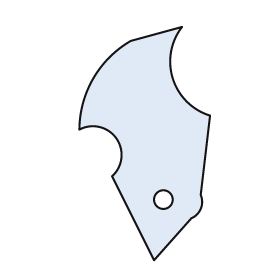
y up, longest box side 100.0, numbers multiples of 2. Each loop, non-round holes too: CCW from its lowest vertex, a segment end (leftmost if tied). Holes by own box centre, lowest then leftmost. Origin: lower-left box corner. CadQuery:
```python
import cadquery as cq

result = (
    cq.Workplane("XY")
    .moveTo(32.0, 0.0)
    .lineTo(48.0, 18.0)
    .threePointArc((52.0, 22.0), (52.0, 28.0))
    .lineTo(56.0, 62.0)
    .threePointArc((40.0, 78.0), (44.0, 100.0))
    .lineTo(22.0, 94.0)
    .threePointArc((6.0, 78.0), (0.0, 56.0))
    .threePointArc((16.0, 52.0), (14.0, 36.0))
    .close()
    .moveTo(36.0, 26.0)
    .circle(4.0)
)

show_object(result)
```